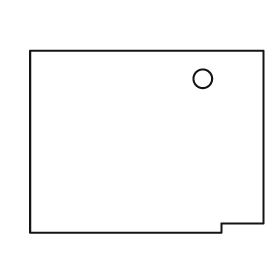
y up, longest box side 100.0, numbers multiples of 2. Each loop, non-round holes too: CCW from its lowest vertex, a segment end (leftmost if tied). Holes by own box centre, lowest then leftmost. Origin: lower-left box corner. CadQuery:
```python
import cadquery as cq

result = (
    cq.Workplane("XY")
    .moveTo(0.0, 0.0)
    .lineTo(82.0, 0.0)
    .lineTo(82.0, 4.0)
    .lineTo(100.0, 4.0)
    .lineTo(100.0, 78.0)
    .lineTo(0.0, 78.0)
    .close()
    .moveTo(74.0, 66.0)
    .circle(4.0)
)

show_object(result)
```